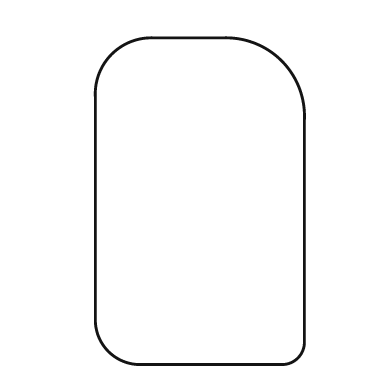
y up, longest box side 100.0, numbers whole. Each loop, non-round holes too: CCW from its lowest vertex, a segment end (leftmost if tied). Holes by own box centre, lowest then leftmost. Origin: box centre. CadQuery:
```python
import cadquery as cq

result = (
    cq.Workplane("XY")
    .moveTo(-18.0, -50.0)
    .lineTo(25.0, -50.0)
    .threePointArc((30.0, -48.0), (32.0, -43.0))
    .lineTo(32.0, 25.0)
    .threePointArc((25.0, 43.0), (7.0, 50.0))
    .lineTo(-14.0, 50.0)
    .threePointArc((-27.0, 45.0), (-32.0, 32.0))
    .lineTo(-32.0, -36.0)
    .threePointArc((-28.0, -46.0), (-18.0, -50.0))
    .close()
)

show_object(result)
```